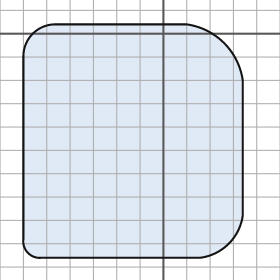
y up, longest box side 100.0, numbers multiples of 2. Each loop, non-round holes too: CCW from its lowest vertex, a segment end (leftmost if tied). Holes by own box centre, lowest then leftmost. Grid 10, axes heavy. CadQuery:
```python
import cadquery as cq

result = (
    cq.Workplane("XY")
    .moveTo(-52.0, -96.0)
    .lineTo(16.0, -96.0)
    .threePointArc((28.0, -90.0), (34.0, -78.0))
    .lineTo(34.0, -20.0)
    .threePointArc((26.0, -4.0), (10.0, 4.0))
    .lineTo(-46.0, 4.0)
    .threePointArc((-56.0, 0.0), (-60.0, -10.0))
    .lineTo(-60.0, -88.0)
    .threePointArc((-58.0, -94.0), (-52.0, -96.0))
    .close()
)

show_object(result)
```